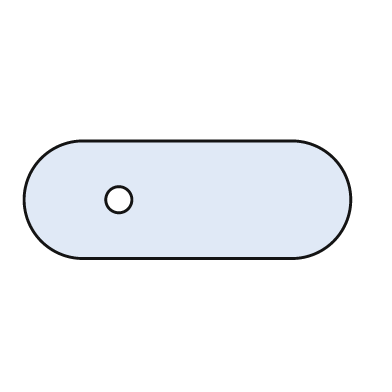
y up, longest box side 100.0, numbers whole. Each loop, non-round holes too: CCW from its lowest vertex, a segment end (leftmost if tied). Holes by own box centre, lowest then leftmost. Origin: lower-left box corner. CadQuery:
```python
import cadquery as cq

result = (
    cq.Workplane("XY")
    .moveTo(18.0, 0.0)
    .lineTo(82.0, 0.0)
    .threePointArc((100.0, 18.0), (82.0, 36.0))
    .lineTo(18.0, 36.0)
    .threePointArc((0.0, 18.0), (18.0, 0.0))
    .close()
    .moveTo(29.0, 18.0)
    .circle(4.0)
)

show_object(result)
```